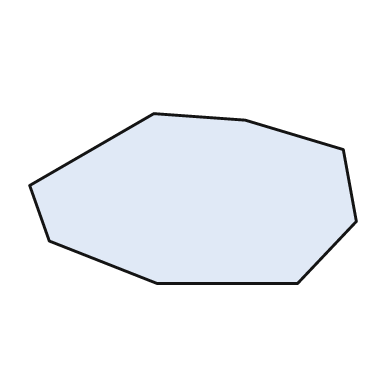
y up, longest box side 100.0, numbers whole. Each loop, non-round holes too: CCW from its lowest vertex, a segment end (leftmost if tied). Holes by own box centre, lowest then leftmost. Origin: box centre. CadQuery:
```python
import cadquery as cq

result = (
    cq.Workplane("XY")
    .moveTo(-11.0, -26.0)
    .lineTo(32.0, -26.0)
    .lineTo(50.0, -7.0)
    .lineTo(46.0, 15.0)
    .lineTo(16.0, 24.0)
    .lineTo(-12.0, 26.0)
    .lineTo(-50.0, 4.0)
    .lineTo(-44.0, -13.0)
    .close()
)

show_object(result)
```